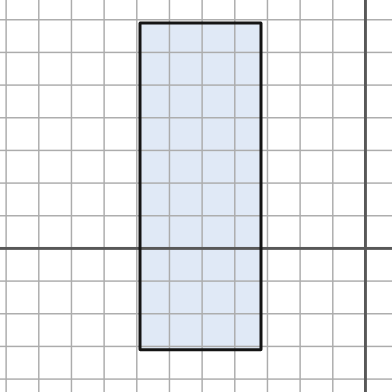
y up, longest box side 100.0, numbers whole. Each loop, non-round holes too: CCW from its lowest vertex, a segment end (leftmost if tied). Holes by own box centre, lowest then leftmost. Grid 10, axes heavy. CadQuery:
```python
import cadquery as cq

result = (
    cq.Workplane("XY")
    .moveTo(-69.0, -31.0)
    .lineTo(-32.0, -31.0)
    .lineTo(-32.0, 69.0)
    .lineTo(-69.0, 69.0)
    .close()
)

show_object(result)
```